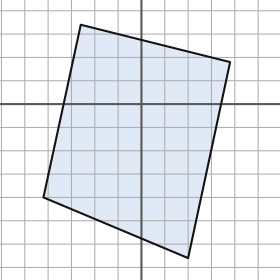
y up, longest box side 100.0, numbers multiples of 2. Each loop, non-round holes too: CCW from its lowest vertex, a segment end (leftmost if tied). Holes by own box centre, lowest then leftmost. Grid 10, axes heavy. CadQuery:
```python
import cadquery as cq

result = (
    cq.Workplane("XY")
    .moveTo(20.0, -66.0)
    .lineTo(38.0, 18.0)
    .lineTo(-26.0, 34.0)
    .lineTo(-42.0, -40.0)
    .close()
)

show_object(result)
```